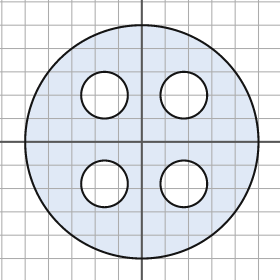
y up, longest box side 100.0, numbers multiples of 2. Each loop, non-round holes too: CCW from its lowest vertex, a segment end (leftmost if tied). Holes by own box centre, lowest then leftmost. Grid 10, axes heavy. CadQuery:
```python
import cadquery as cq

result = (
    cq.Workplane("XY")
    .moveTo(0.0, 0.0)
    .circle(50.0)
    .moveTo(-16.0, -18.0)
    .circle(10.0)
    .moveTo(18.0, -18.0)
    .circle(10.0)
    .moveTo(-16.0, 20.0)
    .circle(10.0)
    .moveTo(18.0, 20.0)
    .circle(10.0)
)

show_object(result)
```